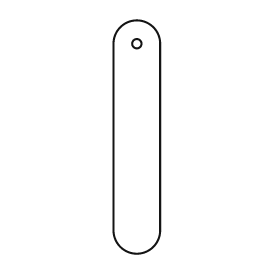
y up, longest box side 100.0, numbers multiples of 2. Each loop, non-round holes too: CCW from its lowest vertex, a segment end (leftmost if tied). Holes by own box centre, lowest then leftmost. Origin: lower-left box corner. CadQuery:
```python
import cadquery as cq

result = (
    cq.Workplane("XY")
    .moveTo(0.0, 10.0)
    .threePointArc((10.0, 0.0), (20.0, 10.0))
    .lineTo(20.0, 90.0)
    .threePointArc((10.0, 100.0), (0.0, 90.0))
    .close()
    .moveTo(10.0, 90.0)
    .circle(2.0)
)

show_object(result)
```